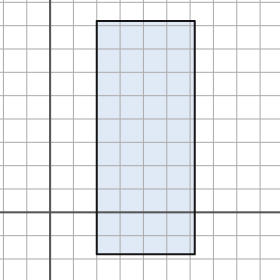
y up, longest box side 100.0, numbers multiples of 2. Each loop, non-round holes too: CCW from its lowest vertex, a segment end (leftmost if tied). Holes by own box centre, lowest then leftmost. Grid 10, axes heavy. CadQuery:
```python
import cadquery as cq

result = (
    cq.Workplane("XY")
    .moveTo(20.0, -18.0)
    .lineTo(62.0, -18.0)
    .lineTo(62.0, 82.0)
    .lineTo(20.0, 82.0)
    .close()
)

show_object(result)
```